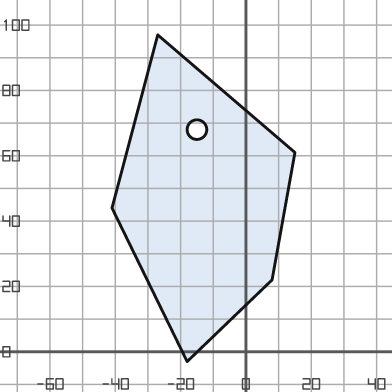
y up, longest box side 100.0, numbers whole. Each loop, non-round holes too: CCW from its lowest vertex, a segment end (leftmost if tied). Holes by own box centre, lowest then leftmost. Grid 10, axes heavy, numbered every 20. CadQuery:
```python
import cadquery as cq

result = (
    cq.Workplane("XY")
    .moveTo(-18.0, -3.0)
    .lineTo(8.0, 22.0)
    .lineTo(15.0, 61.0)
    .lineTo(-27.0, 97.0)
    .lineTo(-41.0, 44.0)
    .close()
    .moveTo(-15.0, 68.0)
    .circle(3.0)
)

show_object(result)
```